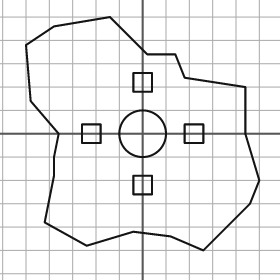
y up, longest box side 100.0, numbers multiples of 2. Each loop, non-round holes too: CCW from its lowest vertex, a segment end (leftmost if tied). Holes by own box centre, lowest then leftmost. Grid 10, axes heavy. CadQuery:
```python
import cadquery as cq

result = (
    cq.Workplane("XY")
    .moveTo(26.0, -50.0)
    .lineTo(46.0, -30.0)
    .lineTo(50.0, -20.0)
    .lineTo(44.0, 0.0)
    .lineTo(44.0, 20.0)
    .lineTo(18.0, 24.0)
    .lineTo(14.0, 34.0)
    .lineTo(2.0, 34.0)
    .lineTo(-14.0, 50.0)
    .lineTo(-38.0, 46.0)
    .lineTo(-50.0, 38.0)
    .lineTo(-48.0, 14.0)
    .lineTo(-36.0, 0.0)
    .lineTo(-38.0, -10.0)
    .lineTo(-38.0, -18.0)
    .lineTo(-42.0, -38.0)
    .lineTo(-24.0, -48.0)
    .lineTo(-4.0, -42.0)
    .lineTo(12.0, -44.0)
    .close()
    .moveTo(-4.0, -26.0)
    .lineTo(4.0, -26.0)
    .lineTo(4.0, -18.0)
    .lineTo(-4.0, -18.0)
    .close()
    .moveTo(-26.0, -4.0)
    .lineTo(-18.0, -4.0)
    .lineTo(-18.0, 4.0)
    .lineTo(-26.0, 4.0)
    .close()
    .moveTo(0.0, 0.0)
    .circle(10.0)
    .moveTo(18.0, -4.0)
    .lineTo(26.0, -4.0)
    .lineTo(26.0, 4.0)
    .lineTo(18.0, 4.0)
    .close()
    .moveTo(-4.0, 18.0)
    .lineTo(4.0, 18.0)
    .lineTo(4.0, 26.0)
    .lineTo(-4.0, 26.0)
    .close()
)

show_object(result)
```